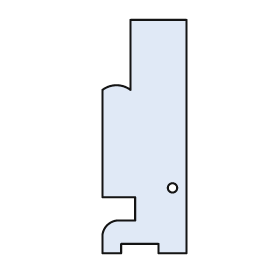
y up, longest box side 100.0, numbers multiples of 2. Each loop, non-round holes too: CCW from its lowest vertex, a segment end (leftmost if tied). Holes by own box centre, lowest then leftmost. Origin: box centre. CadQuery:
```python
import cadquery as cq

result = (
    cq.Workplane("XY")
    .moveTo(-18.0, -50.0)
    .lineTo(-10.0, -50.0)
    .lineTo(-10.0, -46.0)
    .lineTo(6.0, -46.0)
    .lineTo(6.0, -50.0)
    .lineTo(18.0, -50.0)
    .lineTo(18.0, 50.0)
    .lineTo(-6.0, 50.0)
    .lineTo(-6.0, 20.0)
    .threePointArc((-12.0, 22.0), (-18.0, 20.0))
    .lineTo(-18.0, -26.0)
    .lineTo(-4.0, -26.0)
    .lineTo(-4.0, -36.0)
    .lineTo(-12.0, -36.0)
    .threePointArc((-16.0, -38.0), (-18.0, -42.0))
    .close()
    .moveTo(12.0, -22.0)
    .circle(2.0)
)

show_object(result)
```